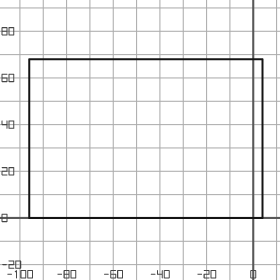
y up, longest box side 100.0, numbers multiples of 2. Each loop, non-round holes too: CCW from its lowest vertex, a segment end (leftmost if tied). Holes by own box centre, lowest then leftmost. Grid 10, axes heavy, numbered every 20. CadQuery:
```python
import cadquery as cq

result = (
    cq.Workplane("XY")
    .moveTo(-96.0, 0.0)
    .lineTo(4.0, 0.0)
    .lineTo(4.0, 68.0)
    .lineTo(-96.0, 68.0)
    .close()
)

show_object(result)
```